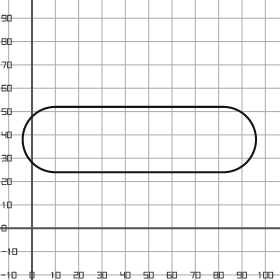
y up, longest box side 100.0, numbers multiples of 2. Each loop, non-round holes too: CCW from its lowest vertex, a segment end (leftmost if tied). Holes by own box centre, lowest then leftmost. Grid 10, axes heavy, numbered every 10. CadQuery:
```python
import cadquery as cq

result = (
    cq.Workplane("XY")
    .moveTo(10.0, 24.0)
    .lineTo(82.0, 24.0)
    .threePointArc((96.0, 38.0), (82.0, 52.0))
    .lineTo(10.0, 52.0)
    .threePointArc((-4.0, 38.0), (10.0, 24.0))
    .close()
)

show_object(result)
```